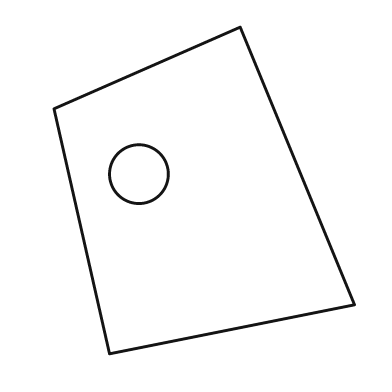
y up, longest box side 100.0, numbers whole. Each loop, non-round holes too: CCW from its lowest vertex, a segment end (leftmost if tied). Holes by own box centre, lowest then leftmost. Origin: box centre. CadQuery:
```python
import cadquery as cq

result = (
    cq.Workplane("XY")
    .moveTo(-29.0, -50.0)
    .lineTo(46.0, -35.0)
    .lineTo(11.0, 50.0)
    .lineTo(-46.0, 25.0)
    .close()
    .moveTo(-20.0, 5.0)
    .circle(9.0)
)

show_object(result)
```